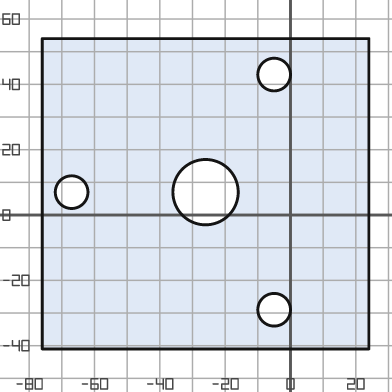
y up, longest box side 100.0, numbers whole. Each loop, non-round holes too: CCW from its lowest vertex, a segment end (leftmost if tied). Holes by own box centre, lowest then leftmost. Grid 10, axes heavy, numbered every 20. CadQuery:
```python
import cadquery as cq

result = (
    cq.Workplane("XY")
    .moveTo(-76.0, -41.0)
    .lineTo(24.0, -41.0)
    .lineTo(24.0, 54.0)
    .lineTo(-76.0, 54.0)
    .close()
    .moveTo(-5.0, -29.0)
    .circle(5.0)
    .moveTo(-67.0, 7.0)
    .circle(5.0)
    .moveTo(-26.0, 7.0)
    .circle(10.0)
    .moveTo(-5.0, 43.0)
    .circle(5.0)
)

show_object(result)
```